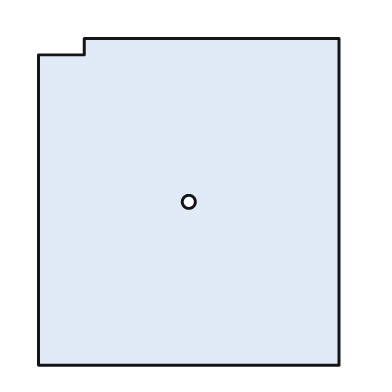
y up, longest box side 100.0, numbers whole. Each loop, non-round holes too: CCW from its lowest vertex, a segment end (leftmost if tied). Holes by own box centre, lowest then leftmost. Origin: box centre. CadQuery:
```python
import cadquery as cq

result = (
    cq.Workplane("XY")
    .moveTo(-46.0, -50.0)
    .lineTo(46.0, -50.0)
    .lineTo(46.0, 50.0)
    .lineTo(-32.0, 50.0)
    .lineTo(-32.0, 45.0)
    .lineTo(-46.0, 45.0)
    .close()
    .moveTo(0.0, 0.0)
    .circle(2.0)
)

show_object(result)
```